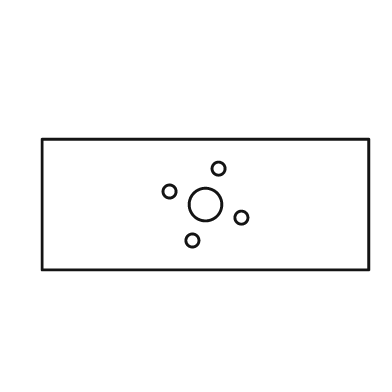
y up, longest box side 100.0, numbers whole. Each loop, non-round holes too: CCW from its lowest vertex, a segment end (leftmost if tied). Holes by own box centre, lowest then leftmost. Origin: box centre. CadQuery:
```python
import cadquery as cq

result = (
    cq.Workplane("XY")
    .moveTo(-50.0, -20.0)
    .lineTo(50.0, -20.0)
    .lineTo(50.0, 20.0)
    .lineTo(-50.0, 20.0)
    .close()
    .moveTo(-4.0, -11.0)
    .circle(2.0)
    .moveTo(11.0, -4.0)
    .circle(2.0)
    .moveTo(0.0, 0.0)
    .circle(5.0)
    .moveTo(-11.0, 4.0)
    .circle(2.0)
    .moveTo(4.0, 11.0)
    .circle(2.0)
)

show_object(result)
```